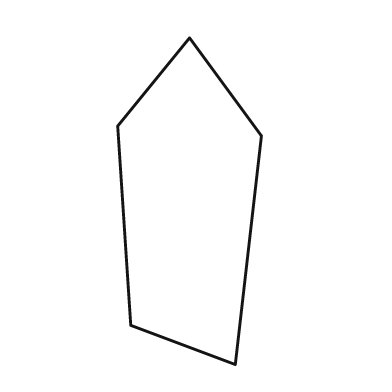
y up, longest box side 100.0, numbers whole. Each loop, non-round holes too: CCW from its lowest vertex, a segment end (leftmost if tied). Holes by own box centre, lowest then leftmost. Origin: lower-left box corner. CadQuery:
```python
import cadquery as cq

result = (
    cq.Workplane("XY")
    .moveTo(36.0, 0.0)
    .lineTo(44.0, 70.0)
    .lineTo(22.0, 100.0)
    .lineTo(0.0, 73.0)
    .lineTo(4.0, 12.0)
    .close()
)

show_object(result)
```